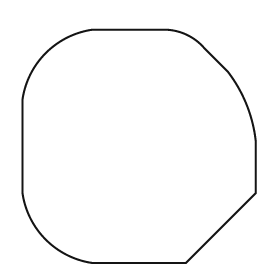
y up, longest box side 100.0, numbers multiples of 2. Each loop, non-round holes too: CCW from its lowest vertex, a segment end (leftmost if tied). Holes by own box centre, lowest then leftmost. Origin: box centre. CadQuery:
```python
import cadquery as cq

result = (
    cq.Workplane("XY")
    .moveTo(-20.0, -50.0)
    .lineTo(20.0, -50.0)
    .lineTo(50.0, -20.0)
    .lineTo(50.0, 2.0)
    .threePointArc((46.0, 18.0), (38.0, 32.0))
    .lineTo(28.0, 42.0)
    .threePointArc((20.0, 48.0), (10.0, 50.0))
    .lineTo(-20.0, 50.0)
    .threePointArc((-40.0, 40.0), (-50.0, 20.0))
    .lineTo(-50.0, -20.0)
    .threePointArc((-40.0, -40.0), (-20.0, -50.0))
    .close()
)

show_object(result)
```